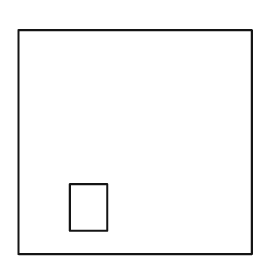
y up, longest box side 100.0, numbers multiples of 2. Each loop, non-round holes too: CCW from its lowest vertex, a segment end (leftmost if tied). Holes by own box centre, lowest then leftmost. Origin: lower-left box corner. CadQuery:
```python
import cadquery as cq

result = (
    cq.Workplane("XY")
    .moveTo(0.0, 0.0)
    .lineTo(100.0, 0.0)
    .lineTo(100.0, 96.0)
    .lineTo(0.0, 96.0)
    .close()
    .moveTo(22.0, 10.0)
    .lineTo(38.0, 10.0)
    .lineTo(38.0, 30.0)
    .lineTo(22.0, 30.0)
    .close()
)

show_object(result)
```